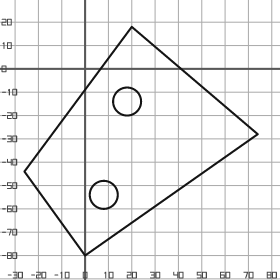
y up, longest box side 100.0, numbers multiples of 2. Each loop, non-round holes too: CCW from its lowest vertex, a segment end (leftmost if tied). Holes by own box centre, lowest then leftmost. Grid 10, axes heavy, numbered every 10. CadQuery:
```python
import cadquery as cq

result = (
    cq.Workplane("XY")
    .moveTo(0.0, -80.0)
    .lineTo(74.0, -28.0)
    .lineTo(20.0, 18.0)
    .lineTo(-26.0, -44.0)
    .close()
    .moveTo(8.0, -54.0)
    .circle(6.0)
    .moveTo(18.0, -14.0)
    .circle(6.0)
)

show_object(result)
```